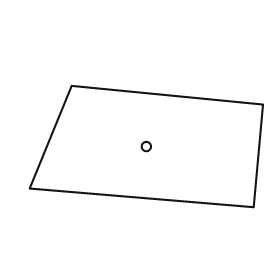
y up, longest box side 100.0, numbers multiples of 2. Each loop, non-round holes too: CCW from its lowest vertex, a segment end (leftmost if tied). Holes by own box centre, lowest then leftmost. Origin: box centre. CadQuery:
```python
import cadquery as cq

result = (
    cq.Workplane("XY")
    .moveTo(46.0, -26.0)
    .lineTo(50.0, 18.0)
    .lineTo(-32.0, 26.0)
    .lineTo(-50.0, -18.0)
    .close()
    .moveTo(0.0, 0.0)
    .circle(2.0)
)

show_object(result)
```